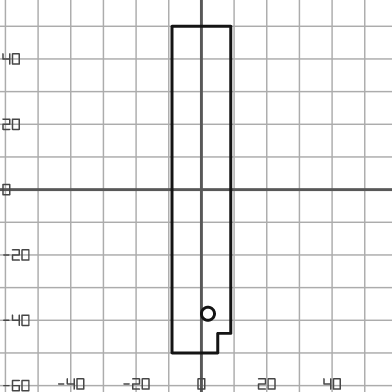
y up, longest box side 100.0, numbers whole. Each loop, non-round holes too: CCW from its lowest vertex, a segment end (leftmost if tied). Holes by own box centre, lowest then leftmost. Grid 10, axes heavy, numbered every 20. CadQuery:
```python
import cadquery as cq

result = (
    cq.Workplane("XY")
    .moveTo(-9.0, -50.0)
    .lineTo(5.0, -50.0)
    .lineTo(5.0, -44.0)
    .lineTo(9.0, -44.0)
    .lineTo(9.0, 50.0)
    .lineTo(-9.0, 50.0)
    .close()
    .moveTo(2.0, -38.0)
    .circle(2.0)
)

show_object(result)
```